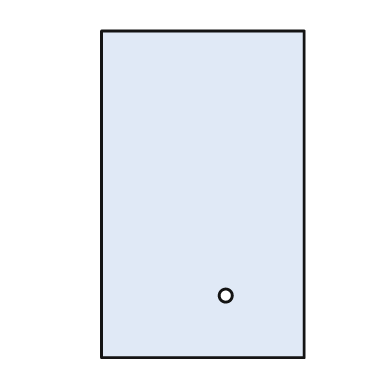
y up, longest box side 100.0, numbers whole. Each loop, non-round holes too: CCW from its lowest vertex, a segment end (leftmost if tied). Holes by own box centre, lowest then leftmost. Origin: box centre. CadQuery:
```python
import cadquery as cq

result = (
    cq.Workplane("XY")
    .moveTo(-31.0, -50.0)
    .lineTo(31.0, -50.0)
    .lineTo(31.0, 50.0)
    .lineTo(-31.0, 50.0)
    .close()
    .moveTo(7.0, -31.0)
    .circle(2.0)
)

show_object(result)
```